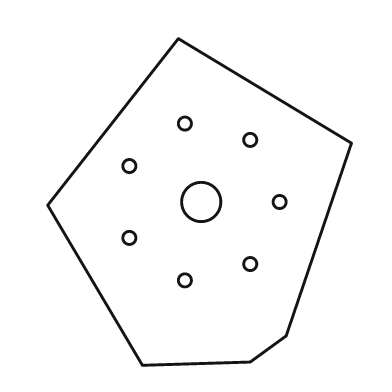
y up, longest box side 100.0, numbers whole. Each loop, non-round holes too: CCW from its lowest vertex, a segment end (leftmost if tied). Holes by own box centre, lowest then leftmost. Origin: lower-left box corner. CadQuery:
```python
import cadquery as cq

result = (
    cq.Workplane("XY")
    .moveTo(29.0, 0.0)
    .lineTo(62.0, 1.0)
    .lineTo(73.0, 9.0)
    .lineTo(93.0, 68.0)
    .lineTo(40.0, 100.0)
    .lineTo(0.0, 49.0)
    .close()
    .moveTo(42.0, 26.0)
    .circle(2.0)
    .moveTo(62.0, 31.0)
    .circle(2.0)
    .moveTo(25.0, 39.0)
    .circle(2.0)
    .moveTo(47.0, 50.0)
    .circle(6.0)
    .moveTo(71.0, 50.0)
    .circle(2.0)
    .moveTo(25.0, 61.0)
    .circle(2.0)
    .moveTo(62.0, 69.0)
    .circle(2.0)
    .moveTo(42.0, 74.0)
    .circle(2.0)
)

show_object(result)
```